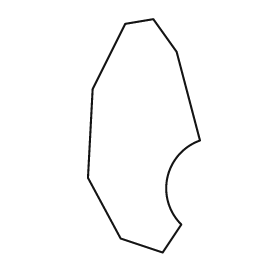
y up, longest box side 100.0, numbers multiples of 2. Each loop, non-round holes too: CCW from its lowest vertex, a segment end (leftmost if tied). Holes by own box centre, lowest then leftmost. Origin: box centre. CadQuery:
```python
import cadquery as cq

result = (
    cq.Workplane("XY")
    .moveTo(8.0, -50.0)
    .lineTo(16.0, -38.0)
    .threePointArc((10.0, -18.0), (24.0, -2.0))
    .lineTo(14.0, 36.0)
    .lineTo(4.0, 50.0)
    .lineTo(-8.0, 48.0)
    .lineTo(-22.0, 20.0)
    .lineTo(-24.0, -18.0)
    .lineTo(-10.0, -44.0)
    .close()
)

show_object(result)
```